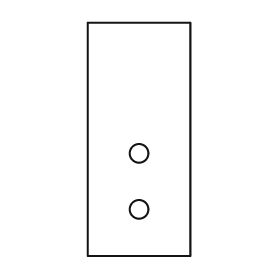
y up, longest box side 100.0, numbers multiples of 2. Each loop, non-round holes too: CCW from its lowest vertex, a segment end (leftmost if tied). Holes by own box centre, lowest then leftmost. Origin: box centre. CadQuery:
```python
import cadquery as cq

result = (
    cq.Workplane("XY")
    .moveTo(-22.0, -50.0)
    .lineTo(22.0, -50.0)
    .lineTo(22.0, 50.0)
    .lineTo(-22.0, 50.0)
    .close()
    .moveTo(0.0, -30.0)
    .circle(4.0)
    .moveTo(0.0, -6.0)
    .circle(4.0)
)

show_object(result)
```